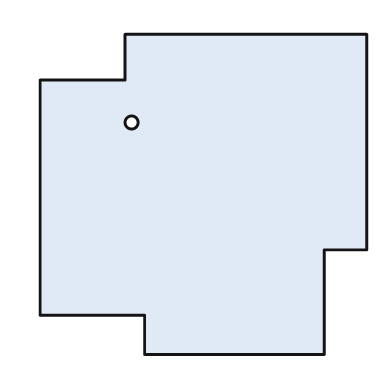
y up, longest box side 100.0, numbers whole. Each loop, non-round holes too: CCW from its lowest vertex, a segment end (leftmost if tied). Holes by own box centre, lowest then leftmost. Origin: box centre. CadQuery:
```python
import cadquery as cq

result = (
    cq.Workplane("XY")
    .moveTo(-18.0, -49.0)
    .lineTo(37.0, -49.0)
    .lineTo(37.0, -17.0)
    .lineTo(50.0, -17.0)
    .lineTo(50.0, 49.0)
    .lineTo(-24.0, 49.0)
    .lineTo(-24.0, 35.0)
    .lineTo(-50.0, 35.0)
    .lineTo(-50.0, -37.0)
    .lineTo(-18.0, -37.0)
    .close()
    .moveTo(-22.0, 22.0)
    .circle(2.0)
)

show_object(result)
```